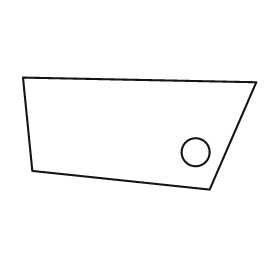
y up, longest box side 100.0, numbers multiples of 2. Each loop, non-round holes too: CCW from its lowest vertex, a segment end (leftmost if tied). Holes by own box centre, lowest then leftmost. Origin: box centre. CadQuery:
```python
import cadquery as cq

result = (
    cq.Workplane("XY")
    .moveTo(30.0, -24.0)
    .lineTo(50.0, 22.0)
    .lineTo(-50.0, 24.0)
    .lineTo(-46.0, -16.0)
    .close()
    .moveTo(24.0, -8.0)
    .circle(6.0)
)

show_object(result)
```